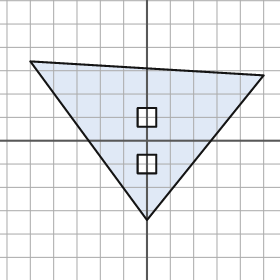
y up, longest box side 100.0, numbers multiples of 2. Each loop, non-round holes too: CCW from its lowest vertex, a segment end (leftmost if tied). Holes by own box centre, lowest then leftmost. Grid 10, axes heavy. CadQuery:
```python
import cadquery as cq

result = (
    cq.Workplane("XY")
    .moveTo(0.0, -34.0)
    .lineTo(50.0, 28.0)
    .lineTo(-50.0, 34.0)
    .close()
    .moveTo(-4.0, -14.0)
    .lineTo(4.0, -14.0)
    .lineTo(4.0, -6.0)
    .lineTo(-4.0, -6.0)
    .close()
    .moveTo(-4.0, 6.0)
    .lineTo(4.0, 6.0)
    .lineTo(4.0, 14.0)
    .lineTo(-4.0, 14.0)
    .close()
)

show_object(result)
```